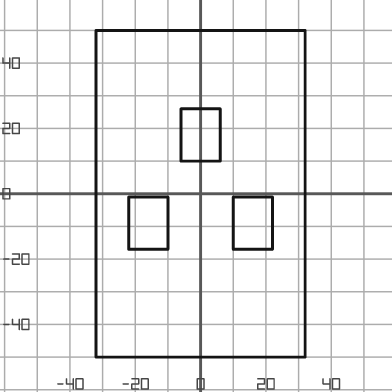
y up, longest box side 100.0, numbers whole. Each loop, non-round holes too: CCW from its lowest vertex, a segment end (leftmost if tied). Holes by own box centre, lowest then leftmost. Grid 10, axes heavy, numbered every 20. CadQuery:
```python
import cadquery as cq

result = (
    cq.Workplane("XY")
    .moveTo(-32.0, -50.0)
    .lineTo(32.0, -50.0)
    .lineTo(32.0, 50.0)
    .lineTo(-32.0, 50.0)
    .close()
    .moveTo(-22.0, -17.0)
    .lineTo(-10.0, -17.0)
    .lineTo(-10.0, -1.0)
    .lineTo(-22.0, -1.0)
    .close()
    .moveTo(10.0, -17.0)
    .lineTo(22.0, -17.0)
    .lineTo(22.0, -1.0)
    .lineTo(10.0, -1.0)
    .close()
    .moveTo(-6.0, 10.0)
    .lineTo(6.0, 10.0)
    .lineTo(6.0, 26.0)
    .lineTo(-6.0, 26.0)
    .close()
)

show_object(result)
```